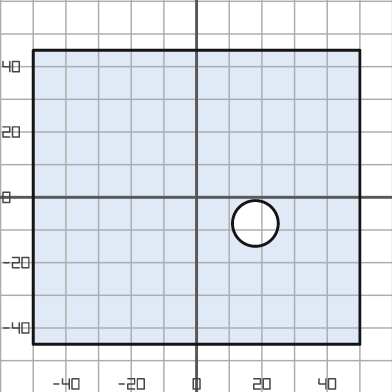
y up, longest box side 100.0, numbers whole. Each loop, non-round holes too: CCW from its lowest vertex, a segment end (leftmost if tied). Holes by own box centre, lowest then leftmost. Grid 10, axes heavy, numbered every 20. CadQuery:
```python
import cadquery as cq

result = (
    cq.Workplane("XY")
    .moveTo(-50.0, -45.0)
    .lineTo(50.0, -45.0)
    .lineTo(50.0, 45.0)
    .lineTo(-50.0, 45.0)
    .close()
    .moveTo(18.0, -8.0)
    .circle(7.0)
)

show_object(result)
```